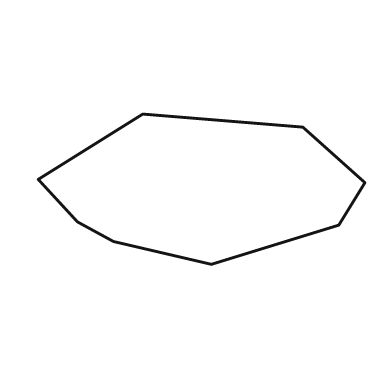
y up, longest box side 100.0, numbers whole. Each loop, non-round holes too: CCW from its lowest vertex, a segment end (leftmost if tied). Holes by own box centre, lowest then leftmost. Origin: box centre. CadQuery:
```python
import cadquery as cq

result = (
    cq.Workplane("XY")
    .moveTo(3.0, -23.0)
    .lineTo(42.0, -11.0)
    .lineTo(50.0, 2.0)
    .lineTo(31.0, 19.0)
    .lineTo(-18.0, 23.0)
    .lineTo(-50.0, 3.0)
    .lineTo(-38.0, -10.0)
    .lineTo(-27.0, -16.0)
    .close()
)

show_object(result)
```